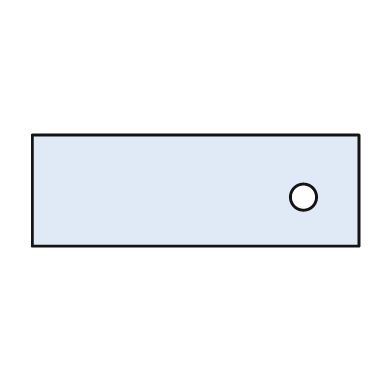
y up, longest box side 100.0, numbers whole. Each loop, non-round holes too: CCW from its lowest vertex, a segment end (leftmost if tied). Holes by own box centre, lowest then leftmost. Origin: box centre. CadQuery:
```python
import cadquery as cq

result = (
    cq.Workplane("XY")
    .moveTo(-50.0, -17.0)
    .lineTo(50.0, -17.0)
    .lineTo(50.0, 17.0)
    .lineTo(-50.0, 17.0)
    .close()
    .moveTo(33.0, -2.0)
    .circle(4.0)
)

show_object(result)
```